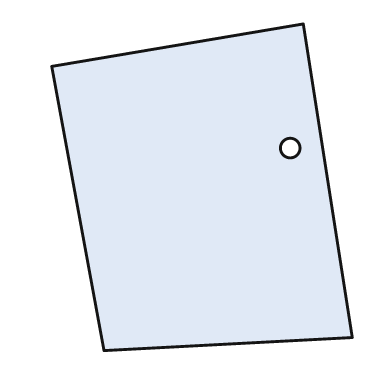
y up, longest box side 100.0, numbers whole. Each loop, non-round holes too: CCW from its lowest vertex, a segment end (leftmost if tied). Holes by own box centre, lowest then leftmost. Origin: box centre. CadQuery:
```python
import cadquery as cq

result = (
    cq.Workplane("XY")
    .moveTo(-30.0, -50.0)
    .lineTo(46.0, -46.0)
    .lineTo(31.0, 50.0)
    .lineTo(-46.0, 37.0)
    .close()
    .moveTo(27.0, 12.0)
    .circle(3.0)
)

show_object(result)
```